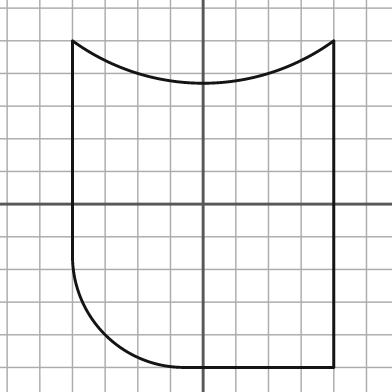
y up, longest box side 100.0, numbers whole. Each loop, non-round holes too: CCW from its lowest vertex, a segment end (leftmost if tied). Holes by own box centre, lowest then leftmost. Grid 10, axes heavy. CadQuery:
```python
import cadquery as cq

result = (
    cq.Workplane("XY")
    .moveTo(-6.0, -50.0)
    .lineTo(40.0, -50.0)
    .lineTo(40.0, 50.0)
    .threePointArc((0.0, 37.0), (-40.0, 50.0))
    .lineTo(-40.0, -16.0)
    .threePointArc((-30.0, -40.0), (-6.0, -50.0))
    .close()
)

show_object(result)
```